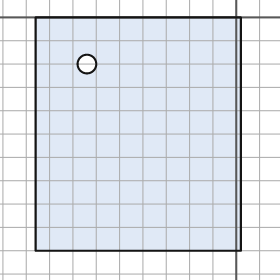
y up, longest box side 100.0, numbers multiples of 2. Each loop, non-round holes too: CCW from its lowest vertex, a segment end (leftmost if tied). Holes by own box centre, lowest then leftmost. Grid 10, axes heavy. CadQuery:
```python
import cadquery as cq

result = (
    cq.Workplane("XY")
    .moveTo(-86.0, -100.0)
    .lineTo(2.0, -100.0)
    .lineTo(2.0, 0.0)
    .lineTo(-86.0, 0.0)
    .close()
    .moveTo(-64.0, -20.0)
    .circle(4.0)
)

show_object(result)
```